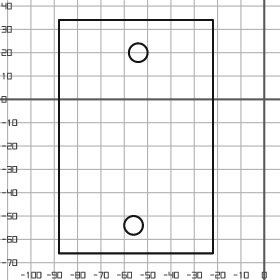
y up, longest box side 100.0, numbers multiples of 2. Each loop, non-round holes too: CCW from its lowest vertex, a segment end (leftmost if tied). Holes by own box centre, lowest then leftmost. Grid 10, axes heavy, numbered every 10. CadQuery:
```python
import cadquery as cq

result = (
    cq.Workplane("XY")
    .moveTo(-88.0, -66.0)
    .lineTo(-22.0, -66.0)
    .lineTo(-22.0, 34.0)
    .lineTo(-88.0, 34.0)
    .close()
    .moveTo(-56.0, -54.0)
    .circle(4.0)
    .moveTo(-54.0, 20.0)
    .circle(4.0)
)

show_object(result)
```